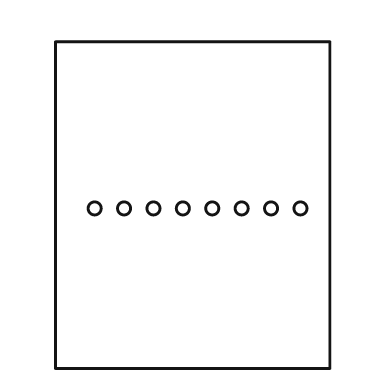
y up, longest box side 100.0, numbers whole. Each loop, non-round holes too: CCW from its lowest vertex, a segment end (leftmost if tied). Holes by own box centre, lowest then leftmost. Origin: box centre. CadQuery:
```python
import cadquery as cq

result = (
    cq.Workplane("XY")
    .moveTo(-42.0, -50.0)
    .lineTo(42.0, -50.0)
    .lineTo(42.0, 50.0)
    .lineTo(-42.0, 50.0)
    .close()
    .moveTo(-30.0, -1.0)
    .circle(2.0)
    .moveTo(-21.0, -1.0)
    .circle(2.0)
    .moveTo(-12.0, -1.0)
    .circle(2.0)
    .moveTo(-3.0, -1.0)
    .circle(2.0)
    .moveTo(6.0, -1.0)
    .circle(2.0)
    .moveTo(15.0, -1.0)
    .circle(2.0)
    .moveTo(24.0, -1.0)
    .circle(2.0)
    .moveTo(33.0, -1.0)
    .circle(2.0)
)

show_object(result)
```